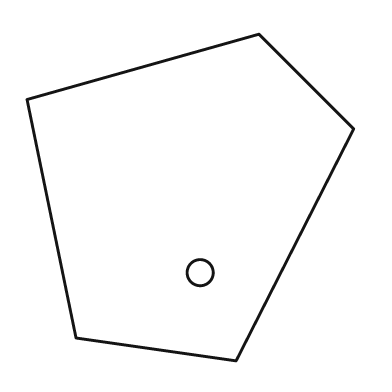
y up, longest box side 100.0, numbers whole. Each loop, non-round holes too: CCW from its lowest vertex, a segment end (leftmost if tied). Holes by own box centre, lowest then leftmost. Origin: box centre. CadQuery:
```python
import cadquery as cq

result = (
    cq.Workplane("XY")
    .moveTo(14.0, -50.0)
    .lineTo(50.0, 21.0)
    .lineTo(21.0, 50.0)
    .lineTo(-50.0, 30.0)
    .lineTo(-35.0, -43.0)
    .close()
    .moveTo(3.0, -23.0)
    .circle(4.0)
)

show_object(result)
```